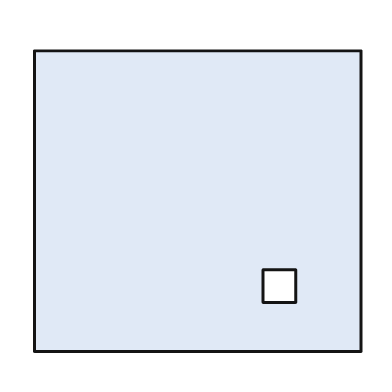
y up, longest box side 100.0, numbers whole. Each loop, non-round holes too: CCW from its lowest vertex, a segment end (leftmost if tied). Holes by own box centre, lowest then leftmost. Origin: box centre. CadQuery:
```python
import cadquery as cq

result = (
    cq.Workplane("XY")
    .moveTo(-50.0, -46.0)
    .lineTo(50.0, -46.0)
    .lineTo(50.0, 46.0)
    .lineTo(-50.0, 46.0)
    .close()
    .moveTo(20.0, -31.0)
    .lineTo(30.0, -31.0)
    .lineTo(30.0, -21.0)
    .lineTo(20.0, -21.0)
    .close()
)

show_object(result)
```